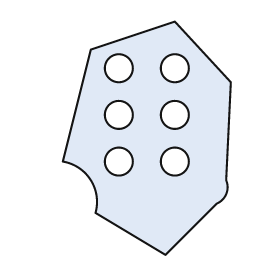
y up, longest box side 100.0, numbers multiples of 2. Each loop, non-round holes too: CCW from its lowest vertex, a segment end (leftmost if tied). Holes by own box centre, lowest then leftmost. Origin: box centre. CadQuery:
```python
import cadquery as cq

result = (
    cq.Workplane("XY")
    .moveTo(8.0, -50.0)
    .lineTo(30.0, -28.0)
    .threePointArc((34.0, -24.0), (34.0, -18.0))
    .lineTo(36.0, 24.0)
    .lineTo(12.0, 50.0)
    .lineTo(-24.0, 38.0)
    .lineTo(-36.0, -10.0)
    .threePointArc((-24.0, -18.0), (-22.0, -32.0))
    .close()
    .moveTo(-12.0, -10.0)
    .circle(6.0)
    .moveTo(12.0, -10.0)
    .circle(6.0)
    .moveTo(-12.0, 10.0)
    .circle(6.0)
    .moveTo(12.0, 10.0)
    .circle(6.0)
    .moveTo(-12.0, 30.0)
    .circle(6.0)
    .moveTo(12.0, 30.0)
    .circle(6.0)
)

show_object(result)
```